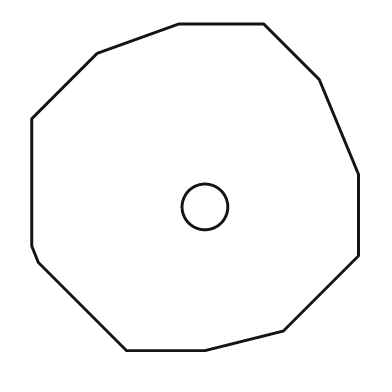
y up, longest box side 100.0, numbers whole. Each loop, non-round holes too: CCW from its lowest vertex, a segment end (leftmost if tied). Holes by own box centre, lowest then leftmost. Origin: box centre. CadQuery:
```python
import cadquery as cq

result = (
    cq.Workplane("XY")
    .moveTo(-21.0, -50.0)
    .lineTo(3.0, -50.0)
    .lineTo(27.0, -44.0)
    .lineTo(50.0, -21.0)
    .lineTo(50.0, 4.0)
    .lineTo(38.0, 33.0)
    .lineTo(21.0, 50.0)
    .lineTo(-5.0, 50.0)
    .lineTo(-30.0, 41.0)
    .lineTo(-50.0, 21.0)
    .lineTo(-50.0, -18.0)
    .lineTo(-48.0, -23.0)
    .close()
    .moveTo(3.0, -6.0)
    .circle(7.0)
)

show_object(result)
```